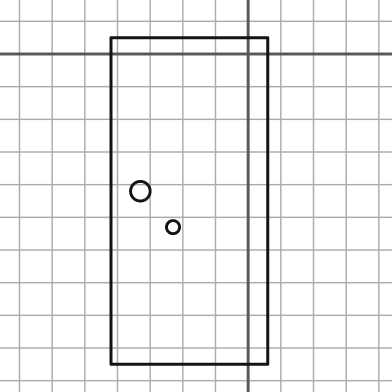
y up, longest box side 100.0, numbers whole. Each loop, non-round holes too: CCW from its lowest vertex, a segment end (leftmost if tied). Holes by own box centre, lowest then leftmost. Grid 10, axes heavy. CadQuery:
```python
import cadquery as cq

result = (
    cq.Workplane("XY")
    .moveTo(-42.0, -95.0)
    .lineTo(6.0, -95.0)
    .lineTo(6.0, 5.0)
    .lineTo(-42.0, 5.0)
    .close()
    .moveTo(-23.0, -53.0)
    .circle(2.0)
    .moveTo(-33.0, -42.0)
    .circle(3.0)
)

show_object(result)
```